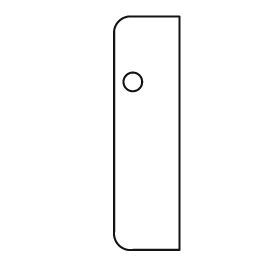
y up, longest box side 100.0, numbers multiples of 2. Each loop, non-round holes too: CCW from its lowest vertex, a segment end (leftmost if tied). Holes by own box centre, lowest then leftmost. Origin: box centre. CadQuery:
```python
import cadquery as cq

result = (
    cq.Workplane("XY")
    .moveTo(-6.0, -50.0)
    .lineTo(14.0, -50.0)
    .lineTo(14.0, 50.0)
    .lineTo(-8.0, 50.0)
    .threePointArc((-12.0, 48.0), (-14.0, 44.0))
    .lineTo(-14.0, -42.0)
    .threePointArc((-12.0, -48.0), (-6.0, -50.0))
    .close()
    .moveTo(-6.0, 22.0)
    .circle(4.0)
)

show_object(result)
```